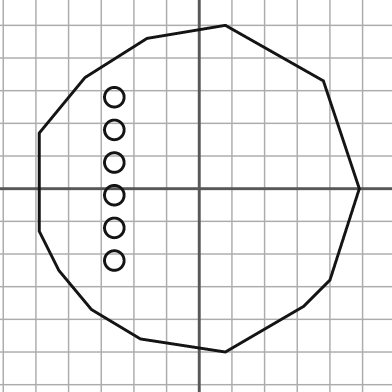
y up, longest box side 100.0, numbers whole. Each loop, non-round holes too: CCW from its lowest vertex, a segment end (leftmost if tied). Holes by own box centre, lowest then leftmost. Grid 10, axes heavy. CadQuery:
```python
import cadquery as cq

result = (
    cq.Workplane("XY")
    .moveTo(8.0, -50.0)
    .lineTo(32.0, -36.0)
    .lineTo(40.0, -28.0)
    .lineTo(49.0, 0.0)
    .lineTo(38.0, 33.0)
    .lineTo(8.0, 50.0)
    .lineTo(-16.0, 46.0)
    .lineTo(-35.0, 34.0)
    .lineTo(-49.0, 17.0)
    .lineTo(-49.0, -13.0)
    .lineTo(-43.0, -25.0)
    .lineTo(-33.0, -37.0)
    .lineTo(-18.0, -46.0)
    .close()
    .moveTo(-26.0, -22.0)
    .circle(3.0)
    .moveTo(-26.0, -12.0)
    .circle(3.0)
    .moveTo(-26.0, -2.0)
    .circle(3.0)
    .moveTo(-26.0, 8.0)
    .circle(3.0)
    .moveTo(-26.0, 18.0)
    .circle(3.0)
    .moveTo(-26.0, 28.0)
    .circle(3.0)
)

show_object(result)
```